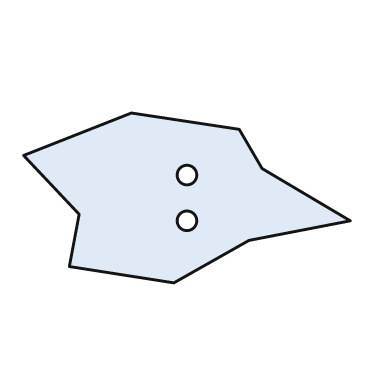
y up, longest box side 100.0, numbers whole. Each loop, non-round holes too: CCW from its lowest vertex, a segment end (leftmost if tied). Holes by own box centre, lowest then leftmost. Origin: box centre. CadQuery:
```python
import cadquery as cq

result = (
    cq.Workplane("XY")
    .moveTo(-4.0, -26.0)
    .lineTo(19.0, -13.0)
    .lineTo(50.0, -7.0)
    .lineTo(23.0, 9.0)
    .lineTo(16.0, 21.0)
    .lineTo(-17.0, 26.0)
    .lineTo(-50.0, 13.0)
    .lineTo(-33.0, -5.0)
    .lineTo(-36.0, -21.0)
    .close()
    .moveTo(0.0, -7.0)
    .circle(3.0)
    .moveTo(0.0, 7.0)
    .circle(3.0)
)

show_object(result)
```